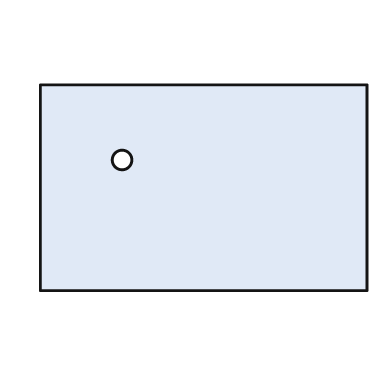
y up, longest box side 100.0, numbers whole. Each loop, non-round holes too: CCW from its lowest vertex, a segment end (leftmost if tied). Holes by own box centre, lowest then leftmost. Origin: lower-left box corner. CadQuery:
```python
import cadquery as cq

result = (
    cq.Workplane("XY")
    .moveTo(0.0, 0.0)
    .lineTo(100.0, 0.0)
    .lineTo(100.0, 63.0)
    .lineTo(0.0, 63.0)
    .close()
    .moveTo(25.0, 40.0)
    .circle(3.0)
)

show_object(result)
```